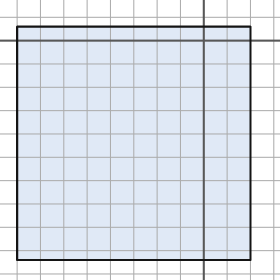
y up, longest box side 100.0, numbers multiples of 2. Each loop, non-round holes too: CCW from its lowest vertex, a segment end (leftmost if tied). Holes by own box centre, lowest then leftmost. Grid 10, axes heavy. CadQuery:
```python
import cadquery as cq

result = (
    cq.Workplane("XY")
    .moveTo(-80.0, -94.0)
    .lineTo(20.0, -94.0)
    .lineTo(20.0, 6.0)
    .lineTo(-80.0, 6.0)
    .close()
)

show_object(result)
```